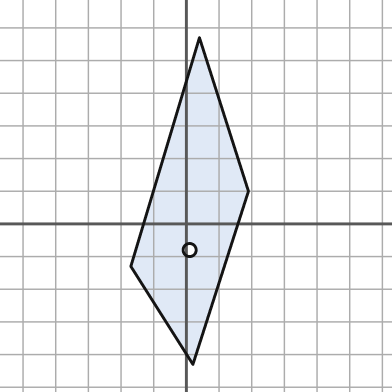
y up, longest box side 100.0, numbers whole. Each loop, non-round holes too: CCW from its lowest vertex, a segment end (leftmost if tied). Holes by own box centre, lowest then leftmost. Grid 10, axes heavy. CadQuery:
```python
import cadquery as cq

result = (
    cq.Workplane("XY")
    .moveTo(2.0, -43.0)
    .lineTo(19.0, 10.0)
    .lineTo(4.0, 57.0)
    .lineTo(-17.0, -13.0)
    .close()
    .moveTo(1.0, -8.0)
    .circle(2.0)
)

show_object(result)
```